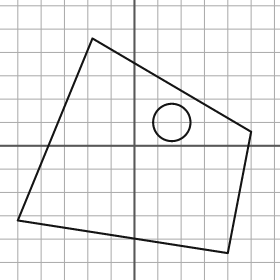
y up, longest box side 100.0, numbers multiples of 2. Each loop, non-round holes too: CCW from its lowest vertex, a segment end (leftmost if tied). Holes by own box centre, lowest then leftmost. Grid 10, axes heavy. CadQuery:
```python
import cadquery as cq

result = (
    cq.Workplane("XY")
    .moveTo(40.0, -46.0)
    .lineTo(50.0, 6.0)
    .lineTo(-18.0, 46.0)
    .lineTo(-50.0, -32.0)
    .close()
    .moveTo(16.0, 10.0)
    .circle(8.0)
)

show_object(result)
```